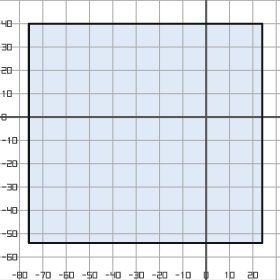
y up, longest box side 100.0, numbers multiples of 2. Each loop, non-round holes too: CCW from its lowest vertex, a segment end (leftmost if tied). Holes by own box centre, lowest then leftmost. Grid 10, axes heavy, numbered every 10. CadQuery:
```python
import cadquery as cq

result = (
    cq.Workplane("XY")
    .moveTo(-76.0, -54.0)
    .lineTo(24.0, -54.0)
    .lineTo(24.0, 40.0)
    .lineTo(-76.0, 40.0)
    .close()
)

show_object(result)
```